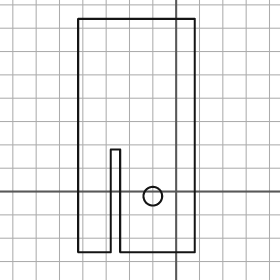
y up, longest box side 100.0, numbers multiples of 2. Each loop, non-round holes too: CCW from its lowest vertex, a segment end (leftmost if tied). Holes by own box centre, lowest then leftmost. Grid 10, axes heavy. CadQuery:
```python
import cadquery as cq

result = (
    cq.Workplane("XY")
    .moveTo(-42.0, -26.0)
    .lineTo(-28.0, -26.0)
    .lineTo(-28.0, 18.0)
    .lineTo(-24.0, 18.0)
    .lineTo(-24.0, -26.0)
    .lineTo(8.0, -26.0)
    .lineTo(8.0, 74.0)
    .lineTo(-42.0, 74.0)
    .close()
    .moveTo(-10.0, -2.0)
    .circle(4.0)
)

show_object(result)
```